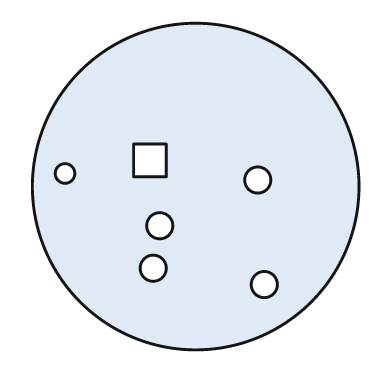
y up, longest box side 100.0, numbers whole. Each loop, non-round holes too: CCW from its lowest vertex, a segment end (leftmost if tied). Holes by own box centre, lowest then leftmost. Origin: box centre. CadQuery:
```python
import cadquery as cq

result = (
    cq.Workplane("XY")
    .moveTo(0.0, 0.0)
    .circle(50.0)
    .moveTo(21.0, -30.0)
    .circle(4.0)
    .moveTo(-13.0, -25.0)
    .circle(4.0)
    .moveTo(-11.0, -12.0)
    .circle(4.0)
    .moveTo(19.0, 2.0)
    .circle(4.0)
    .moveTo(-40.0, 4.0)
    .circle(3.0)
    .moveTo(-19.0, 3.0)
    .lineTo(-9.0, 3.0)
    .lineTo(-9.0, 13.0)
    .lineTo(-19.0, 13.0)
    .close()
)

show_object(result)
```